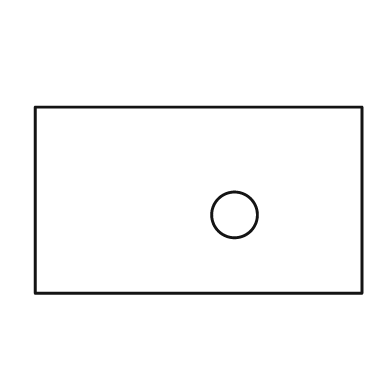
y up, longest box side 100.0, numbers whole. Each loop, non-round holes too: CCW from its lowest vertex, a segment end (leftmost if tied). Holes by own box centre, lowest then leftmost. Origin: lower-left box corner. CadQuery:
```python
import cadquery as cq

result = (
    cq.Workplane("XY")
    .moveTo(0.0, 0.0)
    .lineTo(100.0, 0.0)
    .lineTo(100.0, 57.0)
    .lineTo(0.0, 57.0)
    .close()
    .moveTo(61.0, 24.0)
    .circle(7.0)
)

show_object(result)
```